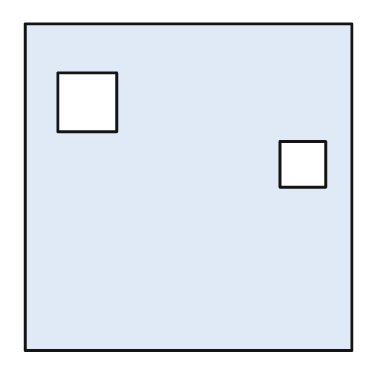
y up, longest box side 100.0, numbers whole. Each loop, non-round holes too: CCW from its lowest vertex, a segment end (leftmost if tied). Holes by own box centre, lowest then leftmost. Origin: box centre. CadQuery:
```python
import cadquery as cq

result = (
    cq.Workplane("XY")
    .moveTo(-50.0, -50.0)
    .lineTo(50.0, -50.0)
    .lineTo(50.0, 50.0)
    .lineTo(-50.0, 50.0)
    .close()
    .moveTo(28.0, 0.0)
    .lineTo(42.0, 0.0)
    .lineTo(42.0, 14.0)
    .lineTo(28.0, 14.0)
    .close()
    .moveTo(-40.0, 17.0)
    .lineTo(-22.0, 17.0)
    .lineTo(-22.0, 35.0)
    .lineTo(-40.0, 35.0)
    .close()
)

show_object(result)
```